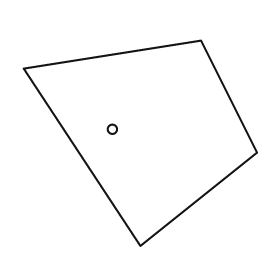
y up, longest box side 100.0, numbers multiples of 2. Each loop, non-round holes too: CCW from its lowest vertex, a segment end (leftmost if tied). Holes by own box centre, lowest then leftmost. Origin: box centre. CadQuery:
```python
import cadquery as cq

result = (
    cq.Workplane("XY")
    .moveTo(0.0, -44.0)
    .lineTo(50.0, -4.0)
    .lineTo(26.0, 44.0)
    .lineTo(-50.0, 32.0)
    .close()
    .moveTo(-12.0, 6.0)
    .circle(2.0)
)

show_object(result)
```